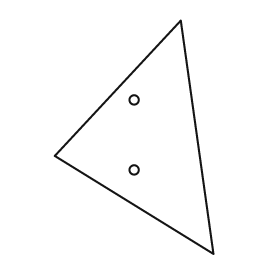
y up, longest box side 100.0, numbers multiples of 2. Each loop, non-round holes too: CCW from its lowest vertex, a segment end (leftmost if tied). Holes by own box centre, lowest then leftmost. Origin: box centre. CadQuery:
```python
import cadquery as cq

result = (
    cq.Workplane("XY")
    .moveTo(34.0, -50.0)
    .lineTo(20.0, 50.0)
    .lineTo(-34.0, -8.0)
    .close()
    .moveTo(0.0, -14.0)
    .circle(2.0)
    .moveTo(0.0, 16.0)
    .circle(2.0)
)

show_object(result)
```